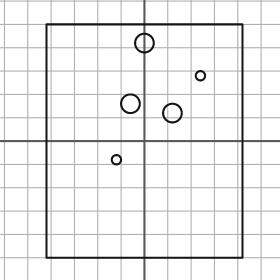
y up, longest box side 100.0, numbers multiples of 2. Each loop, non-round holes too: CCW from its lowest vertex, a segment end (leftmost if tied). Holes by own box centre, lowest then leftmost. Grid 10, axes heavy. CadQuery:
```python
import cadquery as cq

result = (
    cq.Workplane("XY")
    .moveTo(-42.0, -50.0)
    .lineTo(42.0, -50.0)
    .lineTo(42.0, 50.0)
    .lineTo(-42.0, 50.0)
    .close()
    .moveTo(-12.0, -8.0)
    .circle(2.0)
    .moveTo(12.0, 12.0)
    .circle(4.0)
    .moveTo(-6.0, 16.0)
    .circle(4.0)
    .moveTo(24.0, 28.0)
    .circle(2.0)
    .moveTo(0.0, 42.0)
    .circle(4.0)
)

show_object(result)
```